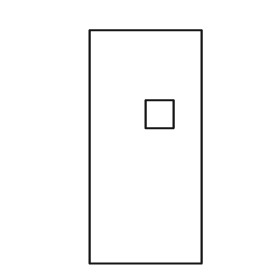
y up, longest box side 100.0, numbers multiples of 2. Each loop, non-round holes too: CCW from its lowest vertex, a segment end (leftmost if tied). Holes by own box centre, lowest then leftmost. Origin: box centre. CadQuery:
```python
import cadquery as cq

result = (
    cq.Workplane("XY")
    .moveTo(-24.0, -50.0)
    .lineTo(24.0, -50.0)
    .lineTo(24.0, 50.0)
    .lineTo(-24.0, 50.0)
    .close()
    .moveTo(0.0, 8.0)
    .lineTo(12.0, 8.0)
    .lineTo(12.0, 20.0)
    .lineTo(0.0, 20.0)
    .close()
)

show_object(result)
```